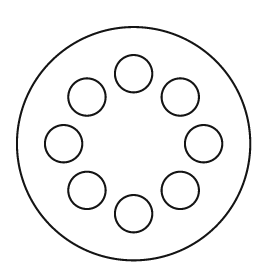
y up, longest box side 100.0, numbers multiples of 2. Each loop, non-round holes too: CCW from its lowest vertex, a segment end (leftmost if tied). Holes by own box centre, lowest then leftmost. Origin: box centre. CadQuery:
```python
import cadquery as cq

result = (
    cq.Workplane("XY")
    .moveTo(0.0, 0.0)
    .circle(50.0)
    .moveTo(0.0, -30.0)
    .circle(8.0)
    .moveTo(-20.0, -20.0)
    .circle(8.0)
    .moveTo(20.0, -20.0)
    .circle(8.0)
    .moveTo(-30.0, 0.0)
    .circle(8.0)
    .moveTo(30.0, 0.0)
    .circle(8.0)
    .moveTo(-20.0, 20.0)
    .circle(8.0)
    .moveTo(20.0, 20.0)
    .circle(8.0)
    .moveTo(0.0, 30.0)
    .circle(8.0)
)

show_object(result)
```